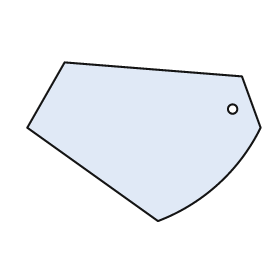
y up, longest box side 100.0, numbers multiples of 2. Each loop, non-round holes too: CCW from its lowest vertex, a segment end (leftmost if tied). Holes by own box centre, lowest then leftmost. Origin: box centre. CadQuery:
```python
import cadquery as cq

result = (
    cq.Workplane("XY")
    .moveTo(6.0, -34.0)
    .threePointArc((32.0, -18.0), (50.0, 6.0))
    .lineTo(42.0, 28.0)
    .lineTo(-34.0, 34.0)
    .lineTo(-50.0, 6.0)
    .close()
    .moveTo(38.0, 14.0)
    .circle(2.0)
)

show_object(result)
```